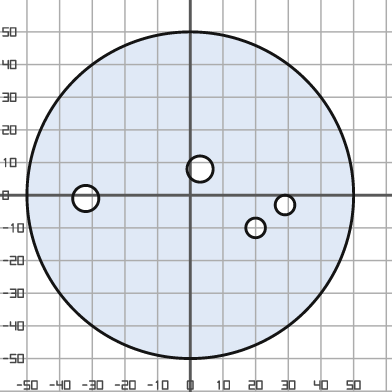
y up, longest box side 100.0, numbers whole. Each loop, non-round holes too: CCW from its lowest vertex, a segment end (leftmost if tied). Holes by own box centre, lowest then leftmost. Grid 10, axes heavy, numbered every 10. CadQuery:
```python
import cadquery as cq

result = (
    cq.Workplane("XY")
    .moveTo(0.0, 0.0)
    .circle(50.0)
    .moveTo(20.0, -10.0)
    .circle(3.0)
    .moveTo(29.0, -3.0)
    .circle(3.0)
    .moveTo(-32.0, -1.0)
    .circle(4.0)
    .moveTo(3.0, 8.0)
    .circle(4.0)
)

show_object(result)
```